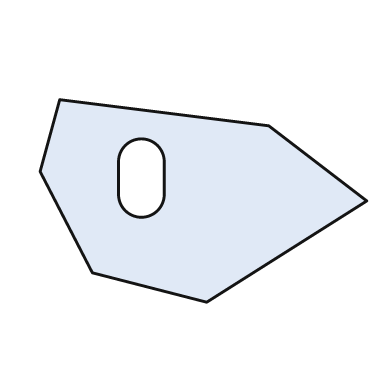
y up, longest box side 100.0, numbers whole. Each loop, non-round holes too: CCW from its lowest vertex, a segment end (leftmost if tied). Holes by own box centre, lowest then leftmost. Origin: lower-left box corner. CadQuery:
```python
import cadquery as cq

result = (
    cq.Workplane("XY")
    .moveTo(51.0, 0.0)
    .lineTo(100.0, 31.0)
    .lineTo(70.0, 54.0)
    .lineTo(6.0, 62.0)
    .lineTo(0.0, 40.0)
    .lineTo(16.0, 9.0)
    .close()
    .moveTo(24.0, 33.0)
    .threePointArc((31.0, 26.0), (38.0, 33.0))
    .lineTo(38.0, 43.0)
    .threePointArc((31.0, 50.0), (24.0, 43.0))
    .close()
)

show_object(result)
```